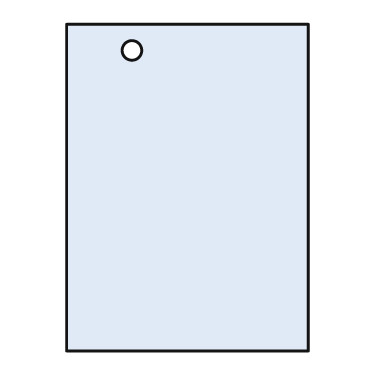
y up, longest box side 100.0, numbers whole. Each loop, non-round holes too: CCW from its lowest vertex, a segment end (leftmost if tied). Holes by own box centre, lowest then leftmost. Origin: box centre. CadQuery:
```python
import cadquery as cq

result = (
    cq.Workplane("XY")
    .moveTo(-37.0, -50.0)
    .lineTo(37.0, -50.0)
    .lineTo(37.0, 50.0)
    .lineTo(-37.0, 50.0)
    .close()
    .moveTo(-17.0, 42.0)
    .circle(3.0)
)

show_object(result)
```